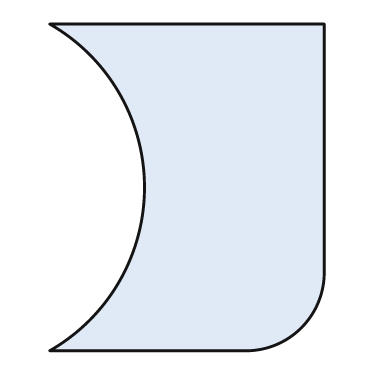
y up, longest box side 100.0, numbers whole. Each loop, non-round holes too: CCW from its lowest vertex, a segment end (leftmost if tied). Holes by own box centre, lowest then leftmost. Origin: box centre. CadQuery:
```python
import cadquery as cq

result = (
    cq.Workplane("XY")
    .moveTo(-42.0, -50.0)
    .lineTo(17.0, -50.0)
    .threePointArc((35.0, -43.0), (42.0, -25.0))
    .lineTo(42.0, 50.0)
    .lineTo(-42.0, 50.0)
    .threePointArc((-13.0, 0.0), (-42.0, -50.0))
    .close()
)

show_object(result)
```